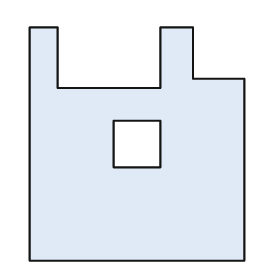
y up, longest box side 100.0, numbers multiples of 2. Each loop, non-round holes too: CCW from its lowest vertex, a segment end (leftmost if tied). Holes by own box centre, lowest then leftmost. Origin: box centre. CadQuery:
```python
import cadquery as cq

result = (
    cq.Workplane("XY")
    .moveTo(-46.0, -50.0)
    .lineTo(46.0, -50.0)
    .lineTo(46.0, 28.0)
    .lineTo(24.0, 28.0)
    .lineTo(24.0, 50.0)
    .lineTo(10.0, 50.0)
    .lineTo(10.0, 24.0)
    .lineTo(-34.0, 24.0)
    .lineTo(-34.0, 50.0)
    .lineTo(-46.0, 50.0)
    .close()
    .moveTo(-10.0, -10.0)
    .lineTo(10.0, -10.0)
    .lineTo(10.0, 10.0)
    .lineTo(-10.0, 10.0)
    .close()
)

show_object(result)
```